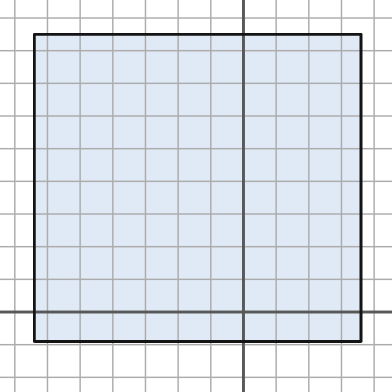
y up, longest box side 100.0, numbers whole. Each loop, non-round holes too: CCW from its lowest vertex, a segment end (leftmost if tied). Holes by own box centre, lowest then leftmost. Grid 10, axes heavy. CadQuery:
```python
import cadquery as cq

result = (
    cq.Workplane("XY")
    .moveTo(-64.0, -9.0)
    .lineTo(36.0, -9.0)
    .lineTo(36.0, 85.0)
    .lineTo(-64.0, 85.0)
    .close()
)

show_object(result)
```